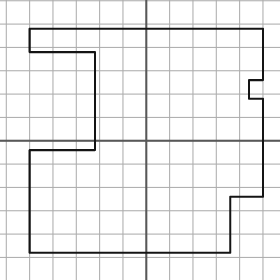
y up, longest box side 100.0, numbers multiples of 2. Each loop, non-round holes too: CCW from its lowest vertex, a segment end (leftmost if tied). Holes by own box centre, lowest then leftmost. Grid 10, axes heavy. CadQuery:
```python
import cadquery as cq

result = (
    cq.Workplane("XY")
    .moveTo(-50.0, -48.0)
    .lineTo(36.0, -48.0)
    .lineTo(36.0, -24.0)
    .lineTo(50.0, -24.0)
    .lineTo(50.0, 18.0)
    .lineTo(44.0, 18.0)
    .lineTo(44.0, 26.0)
    .lineTo(50.0, 26.0)
    .lineTo(50.0, 48.0)
    .lineTo(-50.0, 48.0)
    .lineTo(-50.0, 38.0)
    .lineTo(-22.0, 38.0)
    .lineTo(-22.0, -4.0)
    .lineTo(-50.0, -4.0)
    .close()
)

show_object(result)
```